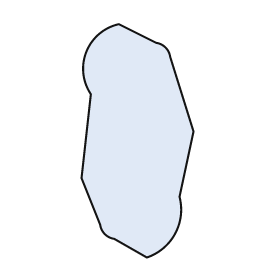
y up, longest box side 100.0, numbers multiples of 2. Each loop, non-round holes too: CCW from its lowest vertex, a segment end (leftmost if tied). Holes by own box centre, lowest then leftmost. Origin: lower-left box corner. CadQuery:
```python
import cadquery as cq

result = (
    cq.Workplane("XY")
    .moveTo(28.0, 0.0)
    .threePointArc((40.0, 10.0), (42.0, 26.0))
    .lineTo(48.0, 54.0)
    .lineTo(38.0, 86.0)
    .threePointArc((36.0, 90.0), (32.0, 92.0))
    .lineTo(16.0, 100.0)
    .threePointArc((2.0, 88.0), (4.0, 70.0))
    .lineTo(0.0, 34.0)
    .lineTo(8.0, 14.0)
    .threePointArc((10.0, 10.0), (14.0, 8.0))
    .close()
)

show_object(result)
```